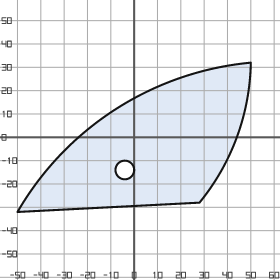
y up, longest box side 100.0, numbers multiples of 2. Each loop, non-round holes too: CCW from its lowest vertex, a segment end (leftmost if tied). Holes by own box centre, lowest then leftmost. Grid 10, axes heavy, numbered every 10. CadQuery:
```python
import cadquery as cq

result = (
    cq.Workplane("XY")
    .moveTo(-50.0, -32.0)
    .lineTo(28.0, -28.0)
    .threePointArc((44.0, 0.0), (50.0, 32.0))
    .threePointArc((-8.0, 12.0), (-50.0, -32.0))
    .close()
    .moveTo(-4.0, -14.0)
    .circle(4.0)
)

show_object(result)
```